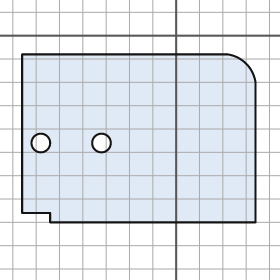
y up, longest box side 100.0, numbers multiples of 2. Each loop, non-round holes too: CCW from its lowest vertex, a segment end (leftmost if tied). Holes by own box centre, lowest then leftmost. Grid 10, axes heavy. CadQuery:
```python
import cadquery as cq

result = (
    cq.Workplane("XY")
    .moveTo(-54.0, -80.0)
    .lineTo(34.0, -80.0)
    .lineTo(34.0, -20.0)
    .threePointArc((30.0, -12.0), (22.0, -8.0))
    .lineTo(-66.0, -8.0)
    .lineTo(-66.0, -76.0)
    .lineTo(-54.0, -76.0)
    .close()
    .moveTo(-58.0, -46.0)
    .circle(4.0)
    .moveTo(-32.0, -46.0)
    .circle(4.0)
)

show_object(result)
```